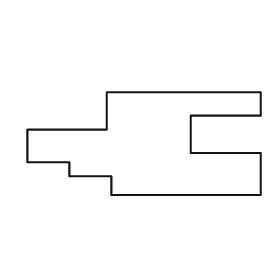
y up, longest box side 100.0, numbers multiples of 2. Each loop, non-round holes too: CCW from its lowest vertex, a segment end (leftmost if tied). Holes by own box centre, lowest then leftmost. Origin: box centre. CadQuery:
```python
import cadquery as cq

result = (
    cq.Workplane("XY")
    .moveTo(-14.0, -22.0)
    .lineTo(50.0, -22.0)
    .lineTo(50.0, -4.0)
    .lineTo(20.0, -4.0)
    .lineTo(20.0, 12.0)
    .lineTo(50.0, 12.0)
    .lineTo(50.0, 22.0)
    .lineTo(-16.0, 22.0)
    .lineTo(-16.0, 6.0)
    .lineTo(-50.0, 6.0)
    .lineTo(-50.0, -8.0)
    .lineTo(-32.0, -8.0)
    .lineTo(-32.0, -14.0)
    .lineTo(-14.0, -14.0)
    .close()
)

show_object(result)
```